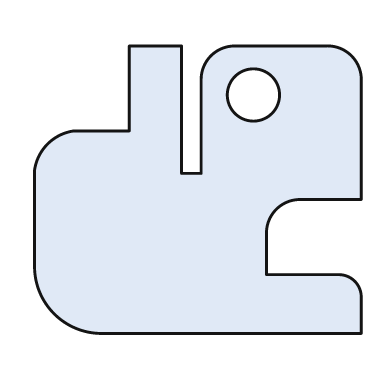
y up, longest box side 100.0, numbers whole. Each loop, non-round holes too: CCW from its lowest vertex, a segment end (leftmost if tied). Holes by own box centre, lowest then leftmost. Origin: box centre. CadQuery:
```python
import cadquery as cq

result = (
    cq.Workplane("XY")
    .moveTo(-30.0, -44.0)
    .lineTo(50.0, -44.0)
    .lineTo(50.0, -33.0)
    .threePointArc((48.0, -28.0), (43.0, -26.0))
    .lineTo(21.0, -26.0)
    .lineTo(21.0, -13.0)
    .threePointArc((24.0, -6.0), (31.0, -3.0))
    .lineTo(50.0, -3.0)
    .lineTo(50.0, 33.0)
    .threePointArc((47.0, 41.0), (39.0, 44.0))
    .lineTo(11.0, 44.0)
    .threePointArc((4.0, 41.0), (1.0, 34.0))
    .lineTo(1.0, 5.0)
    .lineTo(-5.0, 5.0)
    .lineTo(-5.0, 44.0)
    .lineTo(-21.0, 44.0)
    .lineTo(-21.0, 18.0)
    .lineTo(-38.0, 18.0)
    .threePointArc((-46.0, 14.0), (-50.0, 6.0))
    .lineTo(-50.0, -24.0)
    .threePointArc((-44.0, -38.0), (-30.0, -44.0))
    .close()
    .moveTo(17.0, 29.0)
    .circle(8.0)
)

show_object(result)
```